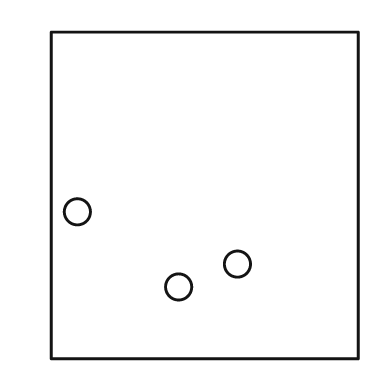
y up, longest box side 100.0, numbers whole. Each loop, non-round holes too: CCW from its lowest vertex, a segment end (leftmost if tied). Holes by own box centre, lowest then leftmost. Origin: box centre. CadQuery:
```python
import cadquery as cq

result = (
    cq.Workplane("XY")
    .moveTo(-47.0, -50.0)
    .lineTo(47.0, -50.0)
    .lineTo(47.0, 50.0)
    .lineTo(-47.0, 50.0)
    .close()
    .moveTo(-8.0, -28.0)
    .circle(4.0)
    .moveTo(10.0, -21.0)
    .circle(4.0)
    .moveTo(-39.0, -5.0)
    .circle(4.0)
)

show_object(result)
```